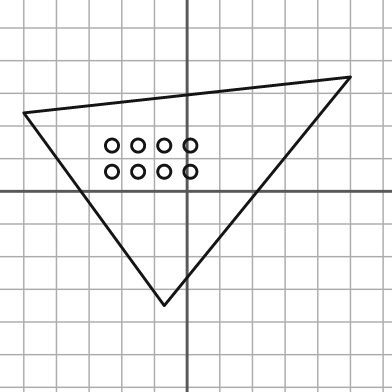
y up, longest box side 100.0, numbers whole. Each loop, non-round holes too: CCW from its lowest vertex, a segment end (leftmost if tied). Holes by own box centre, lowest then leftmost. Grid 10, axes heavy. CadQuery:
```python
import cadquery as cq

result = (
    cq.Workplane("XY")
    .moveTo(-7.0, -35.0)
    .lineTo(50.0, 35.0)
    .lineTo(-50.0, 24.0)
    .close()
    .moveTo(-23.0, 6.0)
    .circle(2.0)
    .moveTo(-15.0, 6.0)
    .circle(2.0)
    .moveTo(-7.0, 6.0)
    .circle(2.0)
    .moveTo(1.0, 6.0)
    .circle(2.0)
    .moveTo(-23.0, 14.0)
    .circle(2.0)
    .moveTo(-15.0, 14.0)
    .circle(2.0)
    .moveTo(-7.0, 14.0)
    .circle(2.0)
    .moveTo(1.0, 14.0)
    .circle(2.0)
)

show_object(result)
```